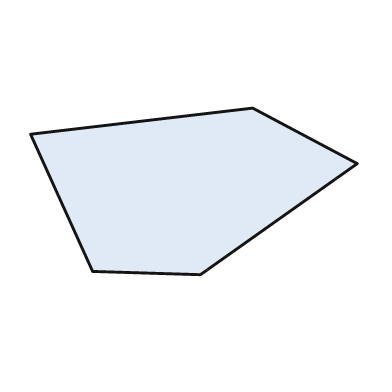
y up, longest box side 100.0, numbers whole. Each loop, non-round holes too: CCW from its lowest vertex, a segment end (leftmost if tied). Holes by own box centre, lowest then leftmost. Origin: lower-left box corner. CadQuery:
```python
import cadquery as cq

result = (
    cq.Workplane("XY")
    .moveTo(52.0, 0.0)
    .lineTo(100.0, 34.0)
    .lineTo(68.0, 51.0)
    .lineTo(0.0, 43.0)
    .lineTo(19.0, 1.0)
    .close()
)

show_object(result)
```